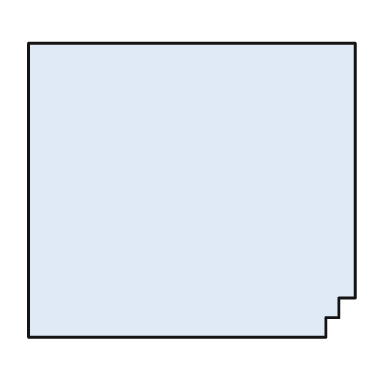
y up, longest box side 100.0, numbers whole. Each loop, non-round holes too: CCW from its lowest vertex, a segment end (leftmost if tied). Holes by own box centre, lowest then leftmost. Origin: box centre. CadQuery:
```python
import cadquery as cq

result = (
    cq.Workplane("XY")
    .moveTo(-50.0, -45.0)
    .lineTo(41.0, -45.0)
    .lineTo(41.0, -39.0)
    .lineTo(45.0, -39.0)
    .lineTo(45.0, -33.0)
    .lineTo(50.0, -33.0)
    .lineTo(50.0, 45.0)
    .lineTo(-50.0, 45.0)
    .close()
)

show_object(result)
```